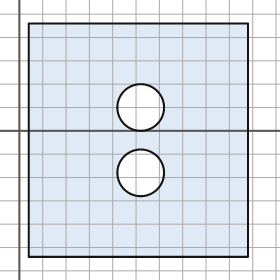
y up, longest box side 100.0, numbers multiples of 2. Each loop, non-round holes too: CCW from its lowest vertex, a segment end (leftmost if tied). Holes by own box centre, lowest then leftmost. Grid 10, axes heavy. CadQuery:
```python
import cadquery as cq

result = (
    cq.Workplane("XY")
    .moveTo(4.0, -54.0)
    .lineTo(98.0, -54.0)
    .lineTo(98.0, 46.0)
    .lineTo(4.0, 46.0)
    .close()
    .moveTo(52.0, -18.0)
    .circle(10.0)
    .moveTo(52.0, 10.0)
    .circle(10.0)
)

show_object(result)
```